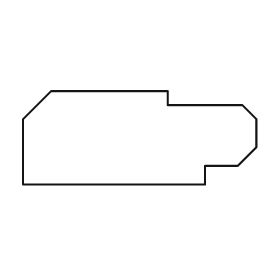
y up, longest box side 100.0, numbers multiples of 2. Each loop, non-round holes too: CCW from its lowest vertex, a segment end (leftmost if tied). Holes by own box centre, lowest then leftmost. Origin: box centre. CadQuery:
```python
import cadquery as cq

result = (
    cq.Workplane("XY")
    .moveTo(-50.0, -20.0)
    .lineTo(28.0, -20.0)
    .lineTo(28.0, -12.0)
    .lineTo(42.0, -12.0)
    .lineTo(50.0, -4.0)
    .lineTo(50.0, 8.0)
    .lineTo(44.0, 14.0)
    .lineTo(12.0, 14.0)
    .lineTo(12.0, 20.0)
    .lineTo(-38.0, 20.0)
    .lineTo(-50.0, 8.0)
    .close()
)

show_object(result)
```